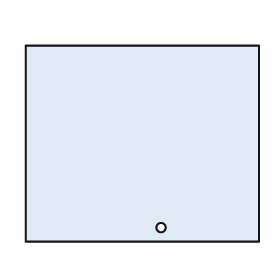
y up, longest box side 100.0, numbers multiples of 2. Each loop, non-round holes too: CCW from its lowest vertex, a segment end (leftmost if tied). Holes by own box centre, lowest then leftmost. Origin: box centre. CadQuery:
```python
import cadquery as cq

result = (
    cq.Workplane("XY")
    .moveTo(-50.0, -42.0)
    .lineTo(50.0, -42.0)
    .lineTo(50.0, 42.0)
    .lineTo(-50.0, 42.0)
    .close()
    .moveTo(8.0, -36.0)
    .circle(2.0)
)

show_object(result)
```